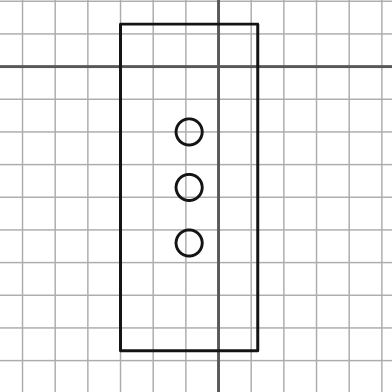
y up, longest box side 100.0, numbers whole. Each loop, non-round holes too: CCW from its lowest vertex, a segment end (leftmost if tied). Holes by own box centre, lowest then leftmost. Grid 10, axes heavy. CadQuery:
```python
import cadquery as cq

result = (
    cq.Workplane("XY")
    .moveTo(-30.0, -87.0)
    .lineTo(12.0, -87.0)
    .lineTo(12.0, 13.0)
    .lineTo(-30.0, 13.0)
    .close()
    .moveTo(-9.0, -54.0)
    .circle(4.0)
    .moveTo(-9.0, -37.0)
    .circle(4.0)
    .moveTo(-9.0, -20.0)
    .circle(4.0)
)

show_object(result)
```